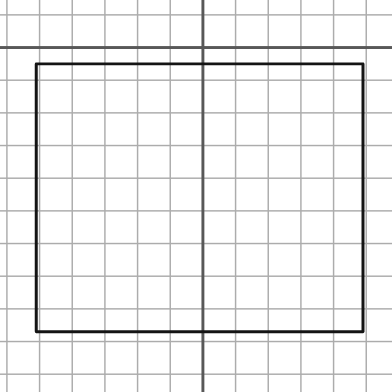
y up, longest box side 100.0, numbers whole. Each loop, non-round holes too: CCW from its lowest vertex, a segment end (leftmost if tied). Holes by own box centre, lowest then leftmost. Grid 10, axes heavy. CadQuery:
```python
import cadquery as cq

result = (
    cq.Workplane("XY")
    .moveTo(-51.0, -87.0)
    .lineTo(49.0, -87.0)
    .lineTo(49.0, -5.0)
    .lineTo(-51.0, -5.0)
    .close()
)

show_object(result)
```